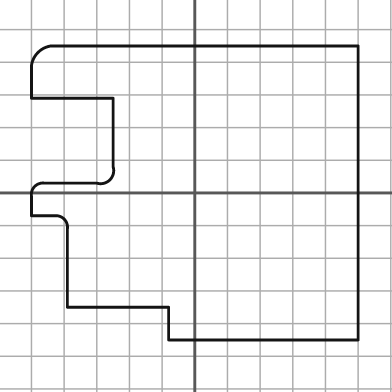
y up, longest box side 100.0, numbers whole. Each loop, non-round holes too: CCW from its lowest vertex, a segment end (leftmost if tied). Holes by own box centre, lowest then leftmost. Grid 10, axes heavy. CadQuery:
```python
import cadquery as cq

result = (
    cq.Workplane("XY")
    .moveTo(-8.0, -45.0)
    .lineTo(50.0, -45.0)
    .lineTo(50.0, 45.0)
    .lineTo(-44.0, 45.0)
    .threePointArc((-48.0, 43.0), (-50.0, 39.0))
    .lineTo(-50.0, 29.0)
    .lineTo(-25.0, 29.0)
    .lineTo(-25.0, 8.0)
    .threePointArc((-26.0, 4.0), (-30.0, 3.0))
    .lineTo(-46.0, 3.0)
    .threePointArc((-49.0, 2.0), (-50.0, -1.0))
    .lineTo(-50.0, -7.0)
    .lineTo(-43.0, -7.0)
    .threePointArc((-40.0, -8.0), (-39.0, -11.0))
    .lineTo(-39.0, -35.0)
    .lineTo(-8.0, -35.0)
    .close()
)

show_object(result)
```